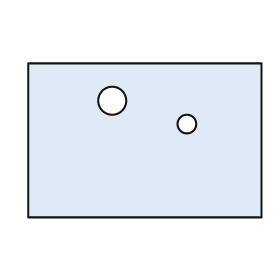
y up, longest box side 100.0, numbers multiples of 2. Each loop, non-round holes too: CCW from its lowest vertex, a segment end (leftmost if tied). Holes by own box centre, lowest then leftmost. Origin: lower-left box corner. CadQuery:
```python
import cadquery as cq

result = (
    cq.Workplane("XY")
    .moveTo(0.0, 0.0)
    .lineTo(100.0, 0.0)
    .lineTo(100.0, 66.0)
    .lineTo(0.0, 66.0)
    .close()
    .moveTo(68.0, 40.0)
    .circle(4.0)
    .moveTo(36.0, 50.0)
    .circle(6.0)
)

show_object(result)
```